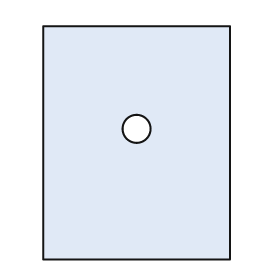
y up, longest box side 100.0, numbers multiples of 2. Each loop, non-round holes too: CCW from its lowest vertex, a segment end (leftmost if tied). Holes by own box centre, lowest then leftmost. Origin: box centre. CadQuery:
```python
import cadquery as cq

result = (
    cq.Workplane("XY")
    .moveTo(-40.0, -50.0)
    .lineTo(40.0, -50.0)
    .lineTo(40.0, 50.0)
    .lineTo(-40.0, 50.0)
    .close()
    .moveTo(0.0, 6.0)
    .circle(6.0)
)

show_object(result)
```